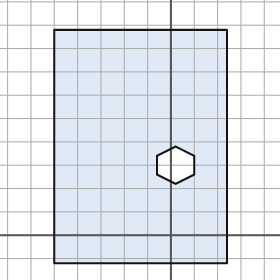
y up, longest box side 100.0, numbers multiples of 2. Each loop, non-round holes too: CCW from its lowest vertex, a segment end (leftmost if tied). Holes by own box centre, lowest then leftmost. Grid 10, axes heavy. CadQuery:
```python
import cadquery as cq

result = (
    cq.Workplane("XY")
    .moveTo(-50.0, -12.0)
    .lineTo(24.0, -12.0)
    .lineTo(24.0, 88.0)
    .lineTo(-50.0, 88.0)
    .close()
    .moveTo(2.0, 22.0)
    .lineTo(10.0, 26.0)
    .lineTo(10.0, 34.0)
    .lineTo(2.0, 38.0)
    .lineTo(-6.0, 34.0)
    .lineTo(-6.0, 26.0)
    .close()
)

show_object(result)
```